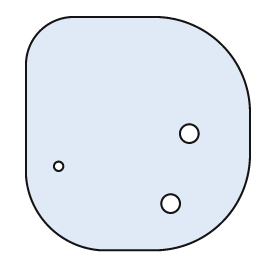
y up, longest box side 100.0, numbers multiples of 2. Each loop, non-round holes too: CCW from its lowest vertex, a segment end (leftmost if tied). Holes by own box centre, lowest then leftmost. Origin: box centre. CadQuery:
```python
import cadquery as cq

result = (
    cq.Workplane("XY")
    .moveTo(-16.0, -50.0)
    .lineTo(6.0, -50.0)
    .threePointArc((36.0, -38.0), (48.0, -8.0))
    .lineTo(48.0, 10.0)
    .threePointArc((36.0, 38.0), (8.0, 50.0))
    .lineTo(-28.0, 50.0)
    .threePointArc((-42.0, 44.0), (-48.0, 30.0))
    .lineTo(-48.0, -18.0)
    .threePointArc((-38.0, -40.0), (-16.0, -50.0))
    .close()
    .moveTo(14.0, -30.0)
    .circle(4.0)
    .moveTo(-34.0, -14.0)
    .circle(2.0)
    .moveTo(22.0, 0.0)
    .circle(4.0)
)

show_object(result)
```